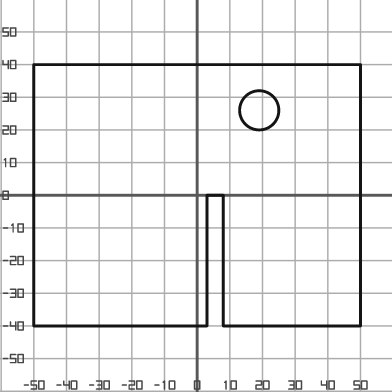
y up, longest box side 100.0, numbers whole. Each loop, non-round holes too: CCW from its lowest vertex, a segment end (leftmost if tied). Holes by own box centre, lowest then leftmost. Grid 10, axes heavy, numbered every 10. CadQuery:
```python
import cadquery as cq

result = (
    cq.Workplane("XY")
    .moveTo(-50.0, -40.0)
    .lineTo(3.0, -40.0)
    .lineTo(3.0, 0.0)
    .lineTo(8.0, 0.0)
    .lineTo(8.0, -40.0)
    .lineTo(50.0, -40.0)
    .lineTo(50.0, 40.0)
    .lineTo(-50.0, 40.0)
    .close()
    .moveTo(19.0, 26.0)
    .circle(6.0)
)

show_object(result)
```